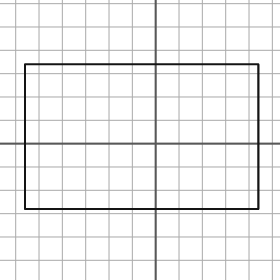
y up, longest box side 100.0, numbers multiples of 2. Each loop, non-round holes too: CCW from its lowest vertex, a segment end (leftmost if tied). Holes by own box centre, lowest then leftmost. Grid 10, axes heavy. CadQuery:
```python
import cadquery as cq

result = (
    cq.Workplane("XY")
    .moveTo(-56.0, -28.0)
    .lineTo(44.0, -28.0)
    .lineTo(44.0, 34.0)
    .lineTo(-56.0, 34.0)
    .close()
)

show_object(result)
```